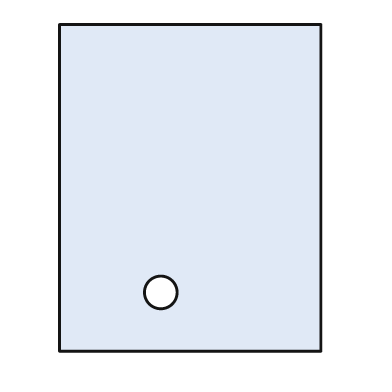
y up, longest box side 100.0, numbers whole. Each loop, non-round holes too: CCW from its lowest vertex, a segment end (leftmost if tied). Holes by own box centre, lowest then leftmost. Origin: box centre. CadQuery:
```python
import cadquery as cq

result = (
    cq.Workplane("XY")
    .moveTo(-40.0, -50.0)
    .lineTo(40.0, -50.0)
    .lineTo(40.0, 50.0)
    .lineTo(-40.0, 50.0)
    .close()
    .moveTo(-9.0, -32.0)
    .circle(5.0)
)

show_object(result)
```